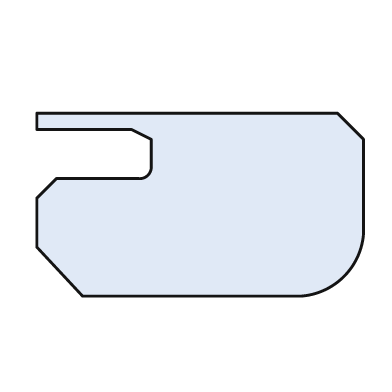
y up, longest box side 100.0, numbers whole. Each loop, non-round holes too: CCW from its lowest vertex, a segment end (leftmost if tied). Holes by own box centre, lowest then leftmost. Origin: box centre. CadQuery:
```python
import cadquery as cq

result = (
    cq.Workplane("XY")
    .moveTo(-36.0, -28.0)
    .lineTo(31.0, -28.0)
    .threePointArc((44.0, -22.0), (50.0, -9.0))
    .lineTo(50.0, 20.0)
    .lineTo(42.0, 28.0)
    .lineTo(-50.0, 28.0)
    .lineTo(-50.0, 23.0)
    .lineTo(-21.0, 23.0)
    .lineTo(-15.0, 20.0)
    .lineTo(-15.0, 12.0)
    .threePointArc((-16.0, 9.0), (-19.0, 8.0))
    .lineTo(-44.0, 8.0)
    .lineTo(-50.0, 2.0)
    .lineTo(-50.0, -13.0)
    .close()
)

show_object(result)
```